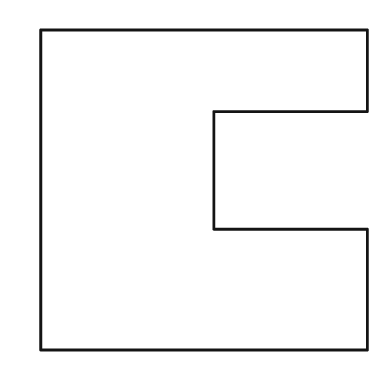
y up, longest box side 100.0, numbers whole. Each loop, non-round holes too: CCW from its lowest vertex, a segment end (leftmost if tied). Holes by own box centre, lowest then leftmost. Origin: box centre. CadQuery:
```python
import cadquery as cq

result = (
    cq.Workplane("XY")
    .moveTo(-50.0, -49.0)
    .lineTo(50.0, -49.0)
    .lineTo(50.0, -12.0)
    .lineTo(3.0, -12.0)
    .lineTo(3.0, 24.0)
    .lineTo(50.0, 24.0)
    .lineTo(50.0, 49.0)
    .lineTo(-50.0, 49.0)
    .close()
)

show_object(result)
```